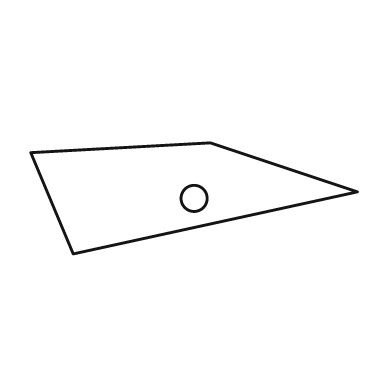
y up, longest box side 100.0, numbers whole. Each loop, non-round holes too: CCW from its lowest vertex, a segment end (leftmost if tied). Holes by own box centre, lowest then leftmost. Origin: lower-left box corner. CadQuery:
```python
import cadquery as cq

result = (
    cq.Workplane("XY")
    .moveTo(13.0, 0.0)
    .lineTo(100.0, 19.0)
    .lineTo(55.0, 34.0)
    .lineTo(0.0, 31.0)
    .close()
    .moveTo(50.0, 17.0)
    .circle(4.0)
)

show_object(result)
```